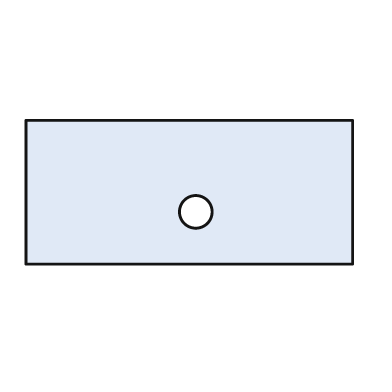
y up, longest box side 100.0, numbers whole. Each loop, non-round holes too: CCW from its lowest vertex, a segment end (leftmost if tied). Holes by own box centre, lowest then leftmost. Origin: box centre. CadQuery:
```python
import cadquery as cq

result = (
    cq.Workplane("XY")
    .moveTo(-50.0, -22.0)
    .lineTo(50.0, -22.0)
    .lineTo(50.0, 22.0)
    .lineTo(-50.0, 22.0)
    .close()
    .moveTo(2.0, -6.0)
    .circle(5.0)
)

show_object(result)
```